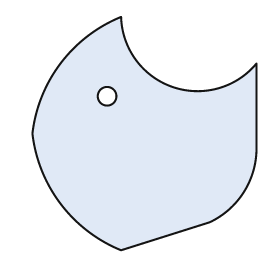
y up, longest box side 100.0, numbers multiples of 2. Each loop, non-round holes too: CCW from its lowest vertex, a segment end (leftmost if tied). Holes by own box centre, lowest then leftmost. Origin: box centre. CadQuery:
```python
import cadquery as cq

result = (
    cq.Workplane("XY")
    .moveTo(-10.0, -50.0)
    .lineTo(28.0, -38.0)
    .threePointArc((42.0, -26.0), (48.0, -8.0))
    .lineTo(48.0, 30.0)
    .threePointArc((12.0, 20.0), (-10.0, 50.0))
    .threePointArc((-36.0, 30.0), (-48.0, 0.0))
    .threePointArc((-36.0, -30.0), (-10.0, -50.0))
    .close()
    .moveTo(-16.0, 16.0)
    .circle(4.0)
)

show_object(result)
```